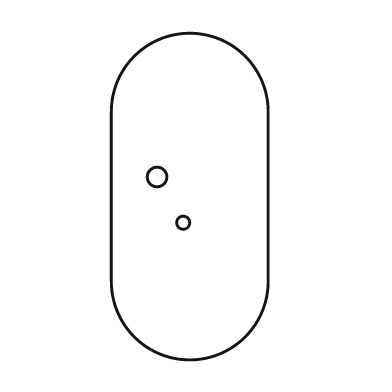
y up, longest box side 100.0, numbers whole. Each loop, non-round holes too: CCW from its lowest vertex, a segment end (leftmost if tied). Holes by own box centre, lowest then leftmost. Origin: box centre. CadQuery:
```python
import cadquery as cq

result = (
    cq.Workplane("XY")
    .moveTo(-24.0, -26.0)
    .threePointArc((0.0, -50.0), (24.0, -26.0))
    .lineTo(24.0, 26.0)
    .threePointArc((0.0, 50.0), (-24.0, 26.0))
    .close()
    .moveTo(-2.0, -8.0)
    .circle(2.0)
    .moveTo(-10.0, 6.0)
    .circle(3.0)
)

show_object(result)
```